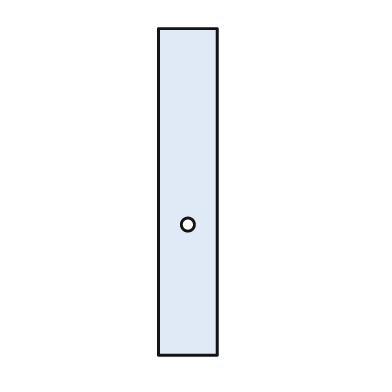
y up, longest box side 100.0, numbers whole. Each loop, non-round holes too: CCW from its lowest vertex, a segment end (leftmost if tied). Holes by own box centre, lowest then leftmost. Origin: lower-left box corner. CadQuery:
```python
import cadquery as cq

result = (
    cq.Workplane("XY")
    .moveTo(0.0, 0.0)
    .lineTo(18.0, 0.0)
    .lineTo(18.0, 100.0)
    .lineTo(0.0, 100.0)
    .close()
    .moveTo(9.0, 40.0)
    .circle(2.0)
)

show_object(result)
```